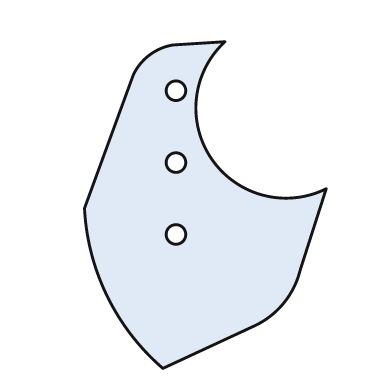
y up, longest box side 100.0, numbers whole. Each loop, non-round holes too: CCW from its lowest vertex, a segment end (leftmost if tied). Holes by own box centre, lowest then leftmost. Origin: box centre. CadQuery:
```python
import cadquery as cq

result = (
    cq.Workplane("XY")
    .moveTo(-13.0, -50.0)
    .lineTo(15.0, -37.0)
    .threePointArc((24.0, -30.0), (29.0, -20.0))
    .lineTo(37.0, 5.0)
    .threePointArc((2.0, 14.0), (6.0, 50.0))
    .lineTo(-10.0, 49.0)
    .threePointArc((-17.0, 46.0), (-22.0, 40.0))
    .lineTo(-37.0, -1.0)
    .threePointArc((-30.0, -28.0), (-13.0, -50.0))
    .close()
    .moveTo(-9.0, -9.0)
    .circle(3.0)
    .moveTo(-9.0, 13.0)
    .circle(3.0)
    .moveTo(-9.0, 35.0)
    .circle(3.0)
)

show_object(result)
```